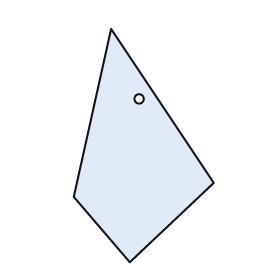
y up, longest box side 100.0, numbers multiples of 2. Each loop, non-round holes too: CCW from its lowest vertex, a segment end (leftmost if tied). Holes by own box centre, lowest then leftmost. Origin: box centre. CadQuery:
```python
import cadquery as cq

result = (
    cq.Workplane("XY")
    .moveTo(-6.0, -50.0)
    .lineTo(30.0, -16.0)
    .lineTo(-14.0, 50.0)
    .lineTo(-30.0, -22.0)
    .close()
    .moveTo(-2.0, 20.0)
    .circle(2.0)
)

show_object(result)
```